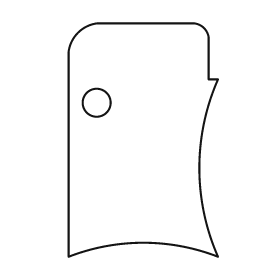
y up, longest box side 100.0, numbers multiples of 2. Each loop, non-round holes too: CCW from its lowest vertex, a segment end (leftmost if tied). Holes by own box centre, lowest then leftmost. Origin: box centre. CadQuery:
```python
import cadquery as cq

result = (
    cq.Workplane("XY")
    .moveTo(-32.0, -50.0)
    .threePointArc((0.0, -44.0), (32.0, -50.0))
    .threePointArc((24.0, -12.0), (32.0, 26.0))
    .lineTo(28.0, 26.0)
    .lineTo(28.0, 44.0)
    .threePointArc((26.0, 48.0), (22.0, 50.0))
    .lineTo(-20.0, 50.0)
    .threePointArc((-28.0, 46.0), (-32.0, 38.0))
    .close()
    .moveTo(-20.0, 16.0)
    .circle(6.0)
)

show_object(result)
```